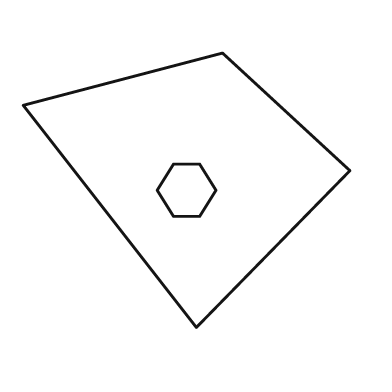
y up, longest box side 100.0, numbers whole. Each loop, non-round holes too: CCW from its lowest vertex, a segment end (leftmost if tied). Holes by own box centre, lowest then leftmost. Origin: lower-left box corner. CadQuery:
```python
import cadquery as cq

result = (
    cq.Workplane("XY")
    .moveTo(53.0, 0.0)
    .lineTo(100.0, 48.0)
    .lineTo(61.0, 84.0)
    .lineTo(0.0, 68.0)
    .close()
    .moveTo(46.0, 34.0)
    .lineTo(54.0, 34.0)
    .lineTo(59.0, 42.0)
    .lineTo(54.0, 50.0)
    .lineTo(46.0, 50.0)
    .lineTo(41.0, 42.0)
    .close()
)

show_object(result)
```